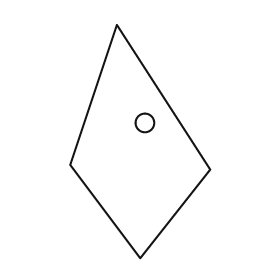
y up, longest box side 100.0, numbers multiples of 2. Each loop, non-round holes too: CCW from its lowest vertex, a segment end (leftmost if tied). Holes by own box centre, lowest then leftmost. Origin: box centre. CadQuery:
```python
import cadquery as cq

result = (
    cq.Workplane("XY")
    .moveTo(0.0, -50.0)
    .lineTo(30.0, -12.0)
    .lineTo(-10.0, 50.0)
    .lineTo(-30.0, -10.0)
    .close()
    .moveTo(2.0, 8.0)
    .circle(4.0)
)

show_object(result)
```